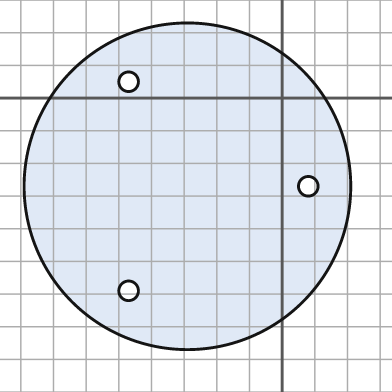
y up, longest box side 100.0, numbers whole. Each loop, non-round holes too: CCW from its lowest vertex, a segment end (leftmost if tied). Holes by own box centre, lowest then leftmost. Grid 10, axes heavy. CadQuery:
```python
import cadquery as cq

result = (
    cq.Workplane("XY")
    .moveTo(-29.0, -27.0)
    .circle(50.0)
    .moveTo(-47.0, -59.0)
    .circle(3.0)
    .moveTo(8.0, -27.0)
    .circle(3.0)
    .moveTo(-47.0, 5.0)
    .circle(3.0)
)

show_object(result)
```